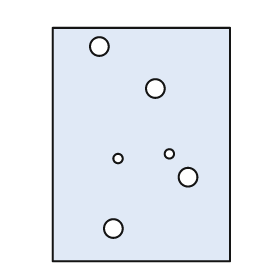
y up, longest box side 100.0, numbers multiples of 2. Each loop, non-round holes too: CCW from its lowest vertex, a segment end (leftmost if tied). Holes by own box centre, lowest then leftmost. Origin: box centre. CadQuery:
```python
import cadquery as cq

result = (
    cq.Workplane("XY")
    .moveTo(-38.0, -50.0)
    .lineTo(38.0, -50.0)
    .lineTo(38.0, 50.0)
    .lineTo(-38.0, 50.0)
    .close()
    .moveTo(-12.0, -36.0)
    .circle(4.0)
    .moveTo(20.0, -14.0)
    .circle(4.0)
    .moveTo(-10.0, -6.0)
    .circle(2.0)
    .moveTo(12.0, -4.0)
    .circle(2.0)
    .moveTo(6.0, 24.0)
    .circle(4.0)
    .moveTo(-18.0, 42.0)
    .circle(4.0)
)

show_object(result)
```